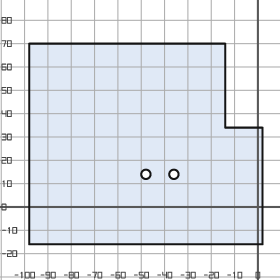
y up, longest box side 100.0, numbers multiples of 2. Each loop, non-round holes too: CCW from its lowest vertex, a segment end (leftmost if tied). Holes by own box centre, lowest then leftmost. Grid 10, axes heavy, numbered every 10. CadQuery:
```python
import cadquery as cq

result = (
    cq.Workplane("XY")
    .moveTo(-98.0, -16.0)
    .lineTo(2.0, -16.0)
    .lineTo(2.0, 34.0)
    .lineTo(-14.0, 34.0)
    .lineTo(-14.0, 70.0)
    .lineTo(-98.0, 70.0)
    .close()
    .moveTo(-48.0, 14.0)
    .circle(2.0)
    .moveTo(-36.0, 14.0)
    .circle(2.0)
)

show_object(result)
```